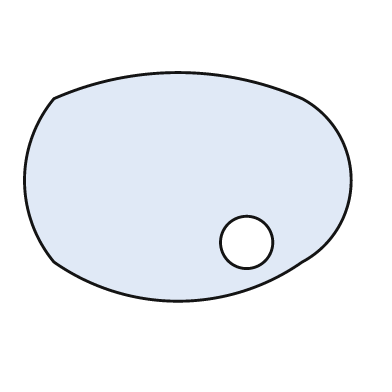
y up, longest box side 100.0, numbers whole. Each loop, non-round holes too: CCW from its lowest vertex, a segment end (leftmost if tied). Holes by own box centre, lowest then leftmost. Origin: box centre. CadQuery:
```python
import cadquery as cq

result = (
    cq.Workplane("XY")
    .moveTo(-41.0, -23.0)
    .threePointArc((-3.0, -35.0), (35.0, -23.0))
    .threePointArc((50.0, 2.0), (35.0, 27.0))
    .threePointArc((-3.0, 35.0), (-41.0, 27.0))
    .threePointArc((-50.0, 2.0), (-41.0, -23.0))
    .close()
    .moveTo(18.0, -17.0)
    .circle(8.0)
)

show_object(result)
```